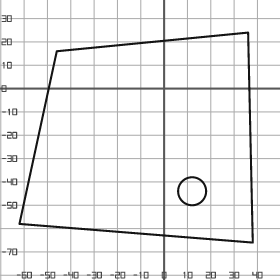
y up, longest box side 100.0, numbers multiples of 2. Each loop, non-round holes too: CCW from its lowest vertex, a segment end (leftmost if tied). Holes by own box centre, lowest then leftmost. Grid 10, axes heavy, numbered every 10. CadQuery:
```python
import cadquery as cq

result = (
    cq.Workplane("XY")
    .moveTo(38.0, -66.0)
    .lineTo(36.0, 24.0)
    .lineTo(-46.0, 16.0)
    .lineTo(-62.0, -58.0)
    .close()
    .moveTo(12.0, -44.0)
    .circle(6.0)
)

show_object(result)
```